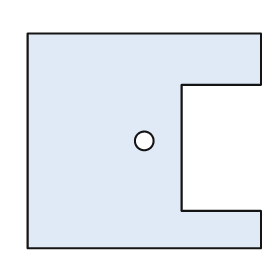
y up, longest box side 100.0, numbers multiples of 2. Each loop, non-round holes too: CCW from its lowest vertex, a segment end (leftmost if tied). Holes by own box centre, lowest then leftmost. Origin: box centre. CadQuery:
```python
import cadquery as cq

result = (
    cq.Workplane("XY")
    .moveTo(-50.0, -46.0)
    .lineTo(50.0, -46.0)
    .lineTo(50.0, -30.0)
    .lineTo(16.0, -30.0)
    .lineTo(16.0, 24.0)
    .lineTo(50.0, 24.0)
    .lineTo(50.0, 46.0)
    .lineTo(-50.0, 46.0)
    .close()
    .moveTo(0.0, 0.0)
    .circle(4.0)
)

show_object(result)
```